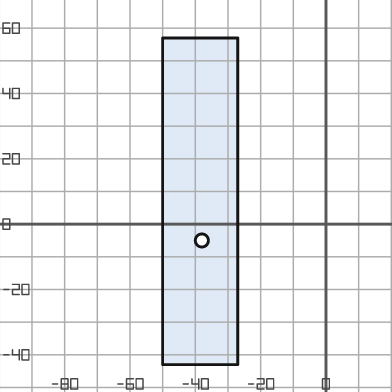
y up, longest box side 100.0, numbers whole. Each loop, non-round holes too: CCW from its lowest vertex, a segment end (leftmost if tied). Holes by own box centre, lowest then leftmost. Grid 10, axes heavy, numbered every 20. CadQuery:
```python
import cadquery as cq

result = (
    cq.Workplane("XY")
    .moveTo(-50.0, -43.0)
    .lineTo(-27.0, -43.0)
    .lineTo(-27.0, 57.0)
    .lineTo(-50.0, 57.0)
    .close()
    .moveTo(-38.0, -5.0)
    .circle(2.0)
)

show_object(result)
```